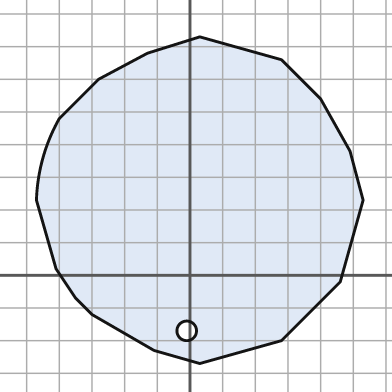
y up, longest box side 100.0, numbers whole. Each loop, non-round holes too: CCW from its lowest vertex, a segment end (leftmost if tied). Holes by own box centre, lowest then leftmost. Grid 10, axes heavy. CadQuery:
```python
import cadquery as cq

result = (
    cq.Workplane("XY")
    .moveTo(3.0, -27.0)
    .lineTo(28.0, -20.0)
    .lineTo(46.0, -2.0)
    .lineTo(53.0, 23.0)
    .lineTo(49.0, 38.0)
    .lineTo(40.0, 54.0)
    .lineTo(28.0, 66.0)
    .lineTo(3.0, 73.0)
    .lineTo(-13.0, 68.0)
    .lineTo(-28.0, 60.0)
    .lineTo(-40.0, 48.0)
    .threePointArc((-45.0, 36.0), (-47.0, 23.0))
    .lineTo(-41.0, 2.0)
    .lineTo(-35.0, -7.0)
    .lineTo(-30.0, -12.0)
    .lineTo(-11.0, -23.0)
    .close()
    .moveTo(-1.0, -17.0)
    .circle(3.0)
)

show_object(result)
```